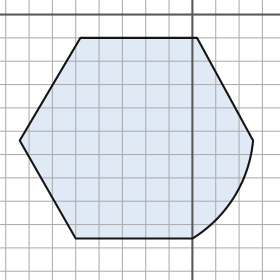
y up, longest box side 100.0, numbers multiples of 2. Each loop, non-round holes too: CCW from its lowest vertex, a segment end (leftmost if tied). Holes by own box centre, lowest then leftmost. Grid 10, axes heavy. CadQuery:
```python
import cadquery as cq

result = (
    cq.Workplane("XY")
    .moveTo(-50.0, -96.0)
    .lineTo(0.0, -96.0)
    .threePointArc((18.0, -78.0), (26.0, -54.0))
    .lineTo(2.0, -10.0)
    .lineTo(-48.0, -10.0)
    .lineTo(-74.0, -54.0)
    .close()
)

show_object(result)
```